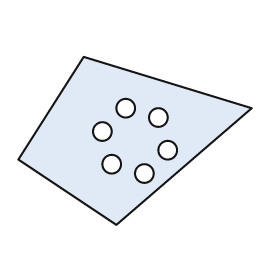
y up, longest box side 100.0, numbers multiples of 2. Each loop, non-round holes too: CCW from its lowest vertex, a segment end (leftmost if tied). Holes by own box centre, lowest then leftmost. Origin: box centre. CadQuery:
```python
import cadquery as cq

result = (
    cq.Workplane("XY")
    .moveTo(-8.0, -36.0)
    .lineTo(50.0, 14.0)
    .lineTo(-22.0, 36.0)
    .lineTo(-50.0, -8.0)
    .close()
    .moveTo(4.0, -14.0)
    .circle(4.0)
    .moveTo(-10.0, -10.0)
    .circle(4.0)
    .moveTo(14.0, -4.0)
    .circle(4.0)
    .moveTo(-14.0, 4.0)
    .circle(4.0)
    .moveTo(10.0, 10.0)
    .circle(4.0)
    .moveTo(-4.0, 14.0)
    .circle(4.0)
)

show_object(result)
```